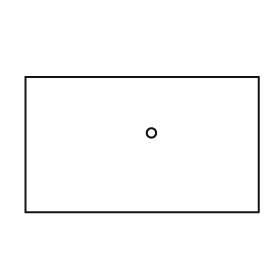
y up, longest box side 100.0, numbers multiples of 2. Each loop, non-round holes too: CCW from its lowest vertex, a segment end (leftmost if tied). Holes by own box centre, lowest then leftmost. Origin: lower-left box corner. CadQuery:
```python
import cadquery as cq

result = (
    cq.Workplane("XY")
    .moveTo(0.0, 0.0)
    .lineTo(100.0, 0.0)
    .lineTo(100.0, 58.0)
    .lineTo(0.0, 58.0)
    .close()
    .moveTo(54.0, 34.0)
    .circle(2.0)
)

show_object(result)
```